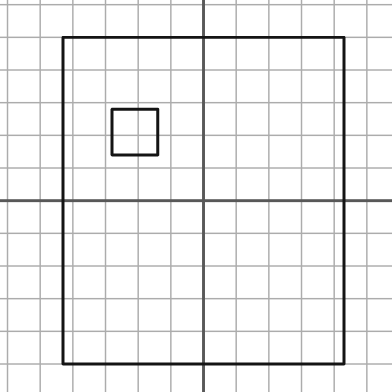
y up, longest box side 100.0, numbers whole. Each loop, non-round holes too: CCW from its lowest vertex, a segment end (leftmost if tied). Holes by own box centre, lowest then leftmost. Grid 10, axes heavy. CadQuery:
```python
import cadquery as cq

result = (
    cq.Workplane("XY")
    .moveTo(-43.0, -50.0)
    .lineTo(43.0, -50.0)
    .lineTo(43.0, 50.0)
    .lineTo(-43.0, 50.0)
    .close()
    .moveTo(-28.0, 14.0)
    .lineTo(-14.0, 14.0)
    .lineTo(-14.0, 28.0)
    .lineTo(-28.0, 28.0)
    .close()
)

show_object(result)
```